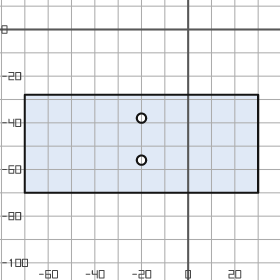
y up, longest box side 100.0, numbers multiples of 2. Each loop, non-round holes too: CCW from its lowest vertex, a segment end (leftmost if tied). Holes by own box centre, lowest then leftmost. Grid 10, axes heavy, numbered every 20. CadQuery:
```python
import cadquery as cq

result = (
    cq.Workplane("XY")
    .moveTo(-70.0, -70.0)
    .lineTo(30.0, -70.0)
    .lineTo(30.0, -28.0)
    .lineTo(-70.0, -28.0)
    .close()
    .moveTo(-20.0, -56.0)
    .circle(2.0)
    .moveTo(-20.0, -38.0)
    .circle(2.0)
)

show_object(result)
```